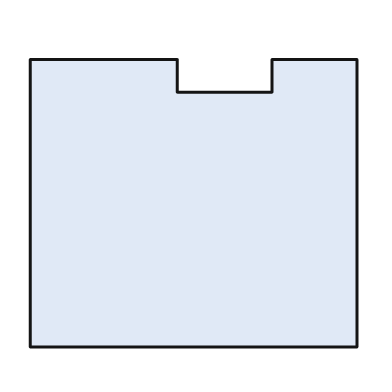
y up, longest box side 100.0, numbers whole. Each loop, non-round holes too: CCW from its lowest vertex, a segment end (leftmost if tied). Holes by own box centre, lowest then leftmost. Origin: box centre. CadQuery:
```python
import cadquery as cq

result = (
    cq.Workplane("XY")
    .moveTo(-50.0, -44.0)
    .lineTo(50.0, -44.0)
    .lineTo(50.0, 44.0)
    .lineTo(24.0, 44.0)
    .lineTo(24.0, 34.0)
    .lineTo(-5.0, 34.0)
    .lineTo(-5.0, 44.0)
    .lineTo(-50.0, 44.0)
    .close()
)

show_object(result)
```